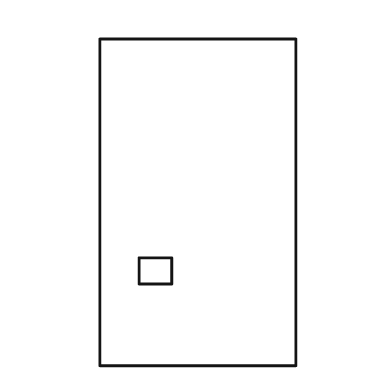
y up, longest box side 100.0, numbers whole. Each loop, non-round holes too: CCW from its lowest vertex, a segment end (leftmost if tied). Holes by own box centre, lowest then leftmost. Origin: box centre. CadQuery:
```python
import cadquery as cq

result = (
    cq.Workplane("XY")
    .moveTo(-30.0, -50.0)
    .lineTo(30.0, -50.0)
    .lineTo(30.0, 50.0)
    .lineTo(-30.0, 50.0)
    .close()
    .moveTo(-18.0, -25.0)
    .lineTo(-8.0, -25.0)
    .lineTo(-8.0, -17.0)
    .lineTo(-18.0, -17.0)
    .close()
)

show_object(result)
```